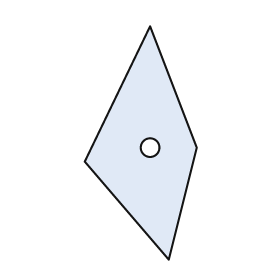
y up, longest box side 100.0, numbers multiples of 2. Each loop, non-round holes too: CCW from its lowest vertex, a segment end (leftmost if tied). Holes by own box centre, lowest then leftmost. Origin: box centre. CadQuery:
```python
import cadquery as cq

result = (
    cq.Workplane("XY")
    .moveTo(12.0, -50.0)
    .lineTo(24.0, -2.0)
    .lineTo(4.0, 50.0)
    .lineTo(-24.0, -8.0)
    .close()
    .moveTo(4.0, -2.0)
    .circle(4.0)
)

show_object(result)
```